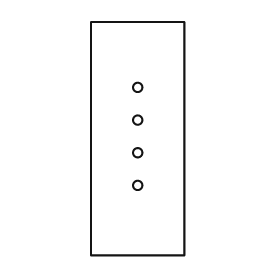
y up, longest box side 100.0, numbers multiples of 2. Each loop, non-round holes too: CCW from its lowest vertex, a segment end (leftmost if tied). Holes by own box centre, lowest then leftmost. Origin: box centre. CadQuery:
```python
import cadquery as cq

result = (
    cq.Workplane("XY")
    .moveTo(-20.0, -50.0)
    .lineTo(20.0, -50.0)
    .lineTo(20.0, 50.0)
    .lineTo(-20.0, 50.0)
    .close()
    .moveTo(0.0, -20.0)
    .circle(2.0)
    .moveTo(0.0, -6.0)
    .circle(2.0)
    .moveTo(0.0, 8.0)
    .circle(2.0)
    .moveTo(0.0, 22.0)
    .circle(2.0)
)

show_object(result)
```